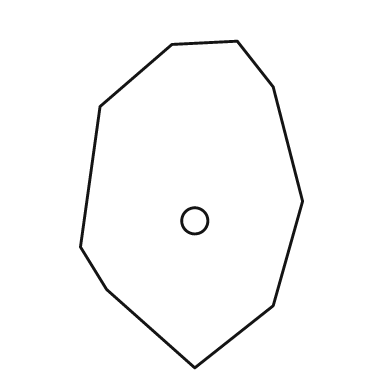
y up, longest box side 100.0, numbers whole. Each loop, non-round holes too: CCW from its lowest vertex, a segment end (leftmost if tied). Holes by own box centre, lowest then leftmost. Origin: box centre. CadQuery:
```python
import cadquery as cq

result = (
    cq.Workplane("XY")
    .moveTo(1.0, -50.0)
    .lineTo(25.0, -31.0)
    .lineTo(34.0, 1.0)
    .lineTo(25.0, 36.0)
    .lineTo(14.0, 50.0)
    .lineTo(-6.0, 49.0)
    .lineTo(-28.0, 30.0)
    .lineTo(-34.0, -13.0)
    .lineTo(-26.0, -26.0)
    .close()
    .moveTo(1.0, -5.0)
    .circle(4.0)
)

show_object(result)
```